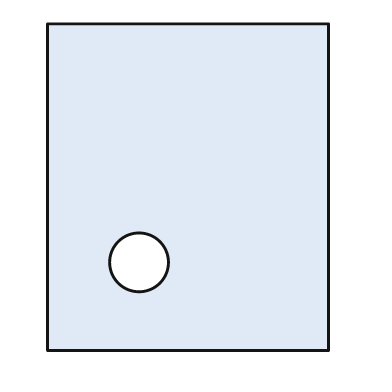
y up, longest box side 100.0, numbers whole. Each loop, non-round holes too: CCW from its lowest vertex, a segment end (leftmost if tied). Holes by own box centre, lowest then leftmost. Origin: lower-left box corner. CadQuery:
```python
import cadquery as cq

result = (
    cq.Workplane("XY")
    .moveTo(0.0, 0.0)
    .lineTo(86.0, 0.0)
    .lineTo(86.0, 100.0)
    .lineTo(0.0, 100.0)
    .close()
    .moveTo(28.0, 27.0)
    .circle(9.0)
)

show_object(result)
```